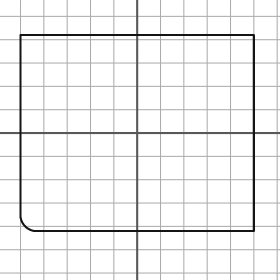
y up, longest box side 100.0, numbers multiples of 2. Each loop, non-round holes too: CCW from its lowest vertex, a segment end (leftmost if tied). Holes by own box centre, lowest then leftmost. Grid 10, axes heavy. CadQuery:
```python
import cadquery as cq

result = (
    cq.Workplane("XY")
    .moveTo(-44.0, -42.0)
    .lineTo(50.0, -42.0)
    .lineTo(50.0, 42.0)
    .lineTo(-50.0, 42.0)
    .lineTo(-50.0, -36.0)
    .threePointArc((-48.0, -40.0), (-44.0, -42.0))
    .close()
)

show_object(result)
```